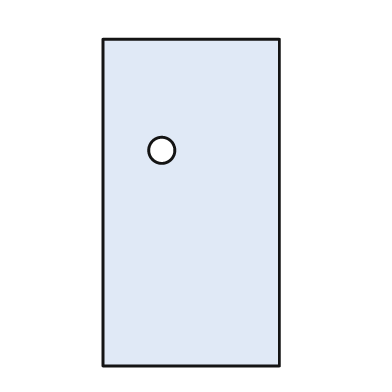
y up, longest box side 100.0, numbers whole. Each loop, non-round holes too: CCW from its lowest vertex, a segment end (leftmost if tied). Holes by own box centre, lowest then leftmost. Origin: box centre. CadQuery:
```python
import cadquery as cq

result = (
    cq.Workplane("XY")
    .moveTo(-27.0, -50.0)
    .lineTo(27.0, -50.0)
    .lineTo(27.0, 50.0)
    .lineTo(-27.0, 50.0)
    .close()
    .moveTo(-9.0, 16.0)
    .circle(4.0)
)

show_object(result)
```